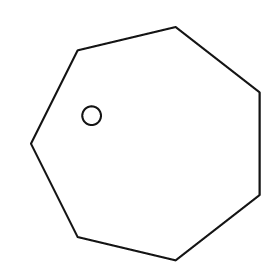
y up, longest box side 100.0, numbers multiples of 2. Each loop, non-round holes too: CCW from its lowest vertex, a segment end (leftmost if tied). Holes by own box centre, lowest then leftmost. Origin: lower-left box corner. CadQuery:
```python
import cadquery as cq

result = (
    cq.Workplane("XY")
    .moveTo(62.0, 0.0)
    .lineTo(98.0, 28.0)
    .lineTo(98.0, 72.0)
    .lineTo(62.0, 100.0)
    .lineTo(20.0, 90.0)
    .lineTo(0.0, 50.0)
    .lineTo(20.0, 10.0)
    .close()
    .moveTo(26.0, 62.0)
    .circle(4.0)
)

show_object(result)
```